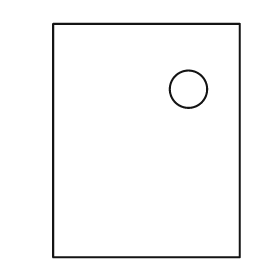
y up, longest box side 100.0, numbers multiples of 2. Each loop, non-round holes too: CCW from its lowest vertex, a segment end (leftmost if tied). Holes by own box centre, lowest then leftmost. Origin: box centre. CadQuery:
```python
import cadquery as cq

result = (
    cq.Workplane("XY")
    .moveTo(-40.0, -50.0)
    .lineTo(40.0, -50.0)
    .lineTo(40.0, 50.0)
    .lineTo(-40.0, 50.0)
    .close()
    .moveTo(18.0, 22.0)
    .circle(8.0)
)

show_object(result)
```